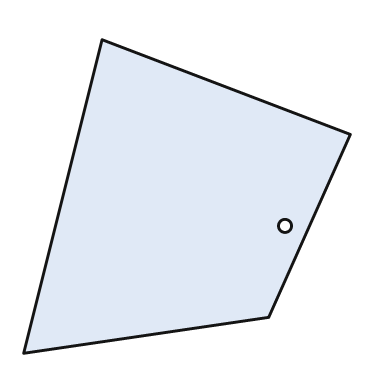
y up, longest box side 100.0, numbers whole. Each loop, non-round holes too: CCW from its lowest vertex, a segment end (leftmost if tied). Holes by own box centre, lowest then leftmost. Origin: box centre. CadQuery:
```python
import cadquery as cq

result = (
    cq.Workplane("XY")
    .moveTo(-50.0, -48.0)
    .lineTo(25.0, -37.0)
    .lineTo(50.0, 19.0)
    .lineTo(-26.0, 48.0)
    .close()
    .moveTo(30.0, -9.0)
    .circle(2.0)
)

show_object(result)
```